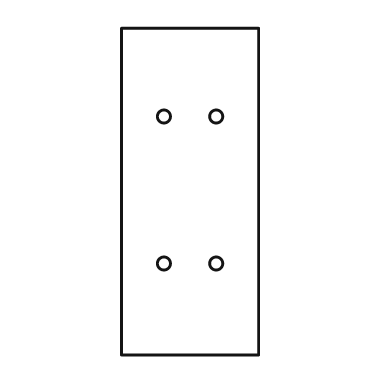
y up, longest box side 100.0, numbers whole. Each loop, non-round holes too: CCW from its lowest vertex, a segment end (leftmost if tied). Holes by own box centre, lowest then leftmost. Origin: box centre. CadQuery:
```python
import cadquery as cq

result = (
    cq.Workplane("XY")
    .moveTo(-21.0, -50.0)
    .lineTo(21.0, -50.0)
    .lineTo(21.0, 50.0)
    .lineTo(-21.0, 50.0)
    .close()
    .moveTo(-8.0, -22.0)
    .circle(2.0)
    .moveTo(8.0, -22.0)
    .circle(2.0)
    .moveTo(-8.0, 23.0)
    .circle(2.0)
    .moveTo(8.0, 23.0)
    .circle(2.0)
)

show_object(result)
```